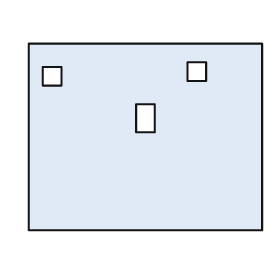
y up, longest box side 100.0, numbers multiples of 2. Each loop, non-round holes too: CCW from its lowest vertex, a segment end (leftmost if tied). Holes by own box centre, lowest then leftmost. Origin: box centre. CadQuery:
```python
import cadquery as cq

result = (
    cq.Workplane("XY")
    .moveTo(-50.0, -40.0)
    .lineTo(50.0, -40.0)
    .lineTo(50.0, 40.0)
    .lineTo(-50.0, 40.0)
    .close()
    .moveTo(-4.0, 2.0)
    .lineTo(4.0, 2.0)
    .lineTo(4.0, 14.0)
    .lineTo(-4.0, 14.0)
    .close()
    .moveTo(-44.0, 22.0)
    .lineTo(-36.0, 22.0)
    .lineTo(-36.0, 30.0)
    .lineTo(-44.0, 30.0)
    .close()
    .moveTo(18.0, 24.0)
    .lineTo(26.0, 24.0)
    .lineTo(26.0, 32.0)
    .lineTo(18.0, 32.0)
    .close()
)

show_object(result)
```